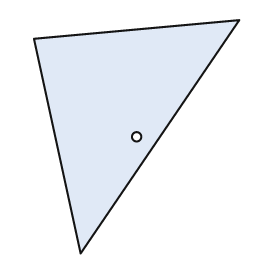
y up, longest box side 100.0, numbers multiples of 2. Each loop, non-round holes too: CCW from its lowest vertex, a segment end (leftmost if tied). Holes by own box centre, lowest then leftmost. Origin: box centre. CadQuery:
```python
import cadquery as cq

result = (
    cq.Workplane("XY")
    .moveTo(-24.0, -50.0)
    .lineTo(44.0, 50.0)
    .lineTo(-44.0, 42.0)
    .close()
    .moveTo(0.0, 0.0)
    .circle(2.0)
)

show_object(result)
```